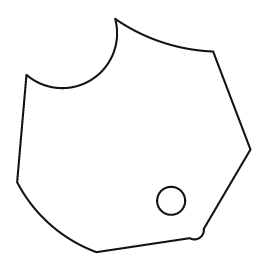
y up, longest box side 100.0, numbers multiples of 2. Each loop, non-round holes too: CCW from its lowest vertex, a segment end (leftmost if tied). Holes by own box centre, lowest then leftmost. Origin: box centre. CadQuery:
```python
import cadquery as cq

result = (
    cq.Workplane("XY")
    .moveTo(-16.0, -50.0)
    .lineTo(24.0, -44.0)
    .threePointArc((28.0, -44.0), (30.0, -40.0))
    .lineTo(50.0, -6.0)
    .lineTo(34.0, 36.0)
    .threePointArc((12.0, 40.0), (-8.0, 50.0))
    .threePointArc((-18.0, 24.0), (-46.0, 26.0))
    .lineTo(-50.0, -20.0)
    .threePointArc((-36.0, -38.0), (-16.0, -50.0))
    .close()
    .moveTo(16.0, -28.0)
    .circle(6.0)
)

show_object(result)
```